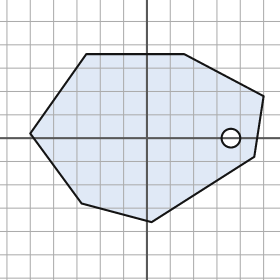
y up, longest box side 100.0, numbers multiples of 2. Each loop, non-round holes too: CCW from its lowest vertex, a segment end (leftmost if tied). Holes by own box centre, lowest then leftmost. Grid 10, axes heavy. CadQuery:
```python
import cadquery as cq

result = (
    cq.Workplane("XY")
    .moveTo(2.0, -36.0)
    .lineTo(46.0, -8.0)
    .lineTo(50.0, 18.0)
    .lineTo(16.0, 36.0)
    .lineTo(-26.0, 36.0)
    .lineTo(-50.0, 2.0)
    .lineTo(-28.0, -28.0)
    .close()
    .moveTo(36.0, 0.0)
    .circle(4.0)
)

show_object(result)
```